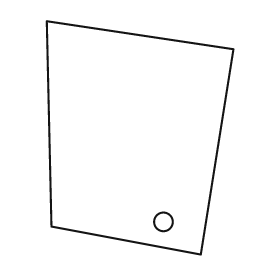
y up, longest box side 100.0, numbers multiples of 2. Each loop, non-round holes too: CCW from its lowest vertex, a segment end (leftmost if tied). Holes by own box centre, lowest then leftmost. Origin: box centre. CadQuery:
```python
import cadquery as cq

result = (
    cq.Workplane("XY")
    .moveTo(26.0, -50.0)
    .lineTo(40.0, 38.0)
    .lineTo(-40.0, 50.0)
    .lineTo(-38.0, -38.0)
    .close()
    .moveTo(10.0, -36.0)
    .circle(4.0)
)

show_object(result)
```